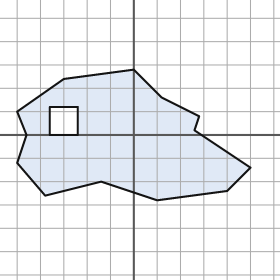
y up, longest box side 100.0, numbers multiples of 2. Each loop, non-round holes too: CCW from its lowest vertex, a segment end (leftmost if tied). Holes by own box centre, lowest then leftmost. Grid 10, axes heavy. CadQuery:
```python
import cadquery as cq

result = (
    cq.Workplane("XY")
    .moveTo(10.0, -28.0)
    .lineTo(40.0, -24.0)
    .lineTo(50.0, -14.0)
    .lineTo(26.0, 2.0)
    .lineTo(28.0, 8.0)
    .lineTo(12.0, 16.0)
    .lineTo(0.0, 28.0)
    .lineTo(-30.0, 24.0)
    .lineTo(-50.0, 10.0)
    .lineTo(-46.0, 0.0)
    .lineTo(-50.0, -12.0)
    .lineTo(-38.0, -26.0)
    .lineTo(-14.0, -20.0)
    .close()
    .moveTo(-36.0, 0.0)
    .lineTo(-24.0, 0.0)
    .lineTo(-24.0, 12.0)
    .lineTo(-36.0, 12.0)
    .close()
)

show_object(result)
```